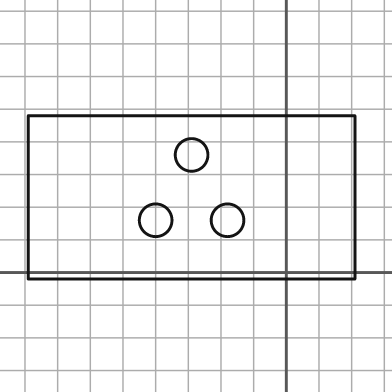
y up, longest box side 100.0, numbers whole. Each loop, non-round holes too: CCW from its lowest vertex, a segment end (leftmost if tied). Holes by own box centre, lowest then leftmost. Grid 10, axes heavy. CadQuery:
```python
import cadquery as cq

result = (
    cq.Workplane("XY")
    .moveTo(-79.0, -2.0)
    .lineTo(21.0, -2.0)
    .lineTo(21.0, 48.0)
    .lineTo(-79.0, 48.0)
    .close()
    .moveTo(-40.0, 16.0)
    .circle(5.0)
    .moveTo(-18.0, 16.0)
    .circle(5.0)
    .moveTo(-29.0, 36.0)
    .circle(5.0)
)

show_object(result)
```